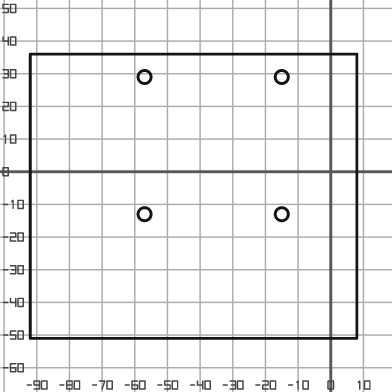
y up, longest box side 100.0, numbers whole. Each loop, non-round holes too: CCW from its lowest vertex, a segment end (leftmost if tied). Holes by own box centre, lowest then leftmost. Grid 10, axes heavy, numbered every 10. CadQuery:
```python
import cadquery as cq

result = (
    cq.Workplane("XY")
    .moveTo(-92.0, -51.0)
    .lineTo(8.0, -51.0)
    .lineTo(8.0, 36.0)
    .lineTo(-92.0, 36.0)
    .close()
    .moveTo(-57.0, -13.0)
    .circle(2.0)
    .moveTo(-15.0, -13.0)
    .circle(2.0)
    .moveTo(-57.0, 29.0)
    .circle(2.0)
    .moveTo(-15.0, 29.0)
    .circle(2.0)
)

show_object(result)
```